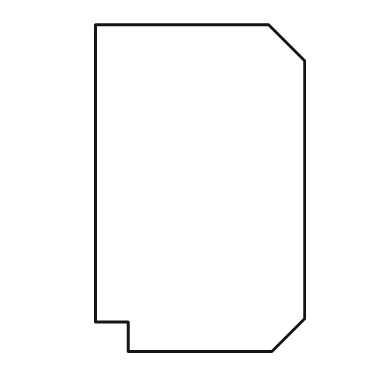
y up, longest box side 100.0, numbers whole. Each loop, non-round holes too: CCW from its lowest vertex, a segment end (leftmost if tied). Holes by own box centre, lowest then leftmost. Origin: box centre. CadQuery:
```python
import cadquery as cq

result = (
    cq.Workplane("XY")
    .moveTo(-22.0, -50.0)
    .lineTo(22.0, -50.0)
    .lineTo(32.0, -40.0)
    .lineTo(32.0, 39.0)
    .lineTo(21.0, 50.0)
    .lineTo(-32.0, 50.0)
    .lineTo(-32.0, -41.0)
    .lineTo(-22.0, -41.0)
    .close()
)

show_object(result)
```